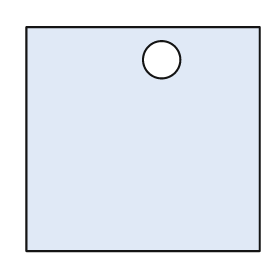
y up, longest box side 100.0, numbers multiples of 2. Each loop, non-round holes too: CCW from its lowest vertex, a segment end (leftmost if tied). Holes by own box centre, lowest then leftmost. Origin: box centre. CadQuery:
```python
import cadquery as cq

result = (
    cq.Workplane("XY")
    .moveTo(-50.0, -48.0)
    .lineTo(50.0, -48.0)
    .lineTo(50.0, 48.0)
    .lineTo(-50.0, 48.0)
    .close()
    .moveTo(8.0, 34.0)
    .circle(8.0)
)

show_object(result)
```